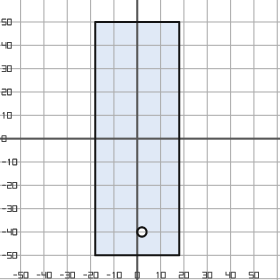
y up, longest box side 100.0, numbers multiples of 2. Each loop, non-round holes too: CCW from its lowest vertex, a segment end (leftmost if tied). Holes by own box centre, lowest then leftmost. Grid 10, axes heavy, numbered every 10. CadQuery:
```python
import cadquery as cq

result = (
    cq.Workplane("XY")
    .moveTo(-18.0, -50.0)
    .lineTo(18.0, -50.0)
    .lineTo(18.0, 50.0)
    .lineTo(-18.0, 50.0)
    .close()
    .moveTo(2.0, -40.0)
    .circle(2.0)
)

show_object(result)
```